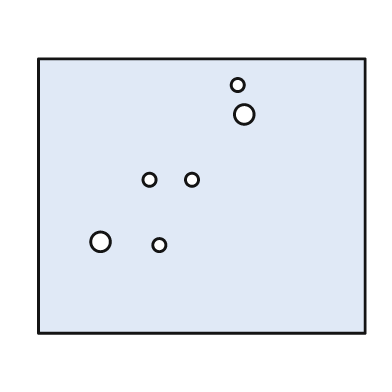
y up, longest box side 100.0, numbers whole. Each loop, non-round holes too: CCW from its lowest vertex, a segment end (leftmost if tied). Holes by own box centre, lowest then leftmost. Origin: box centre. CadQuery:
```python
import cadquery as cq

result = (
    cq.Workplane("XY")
    .moveTo(-50.0, -42.0)
    .lineTo(50.0, -42.0)
    .lineTo(50.0, 42.0)
    .lineTo(-50.0, 42.0)
    .close()
    .moveTo(-13.0, -15.0)
    .circle(2.0)
    .moveTo(-31.0, -14.0)
    .circle(3.0)
    .moveTo(-16.0, 5.0)
    .circle(2.0)
    .moveTo(-3.0, 5.0)
    .circle(2.0)
    .moveTo(13.0, 25.0)
    .circle(3.0)
    .moveTo(11.0, 34.0)
    .circle(2.0)
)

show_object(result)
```